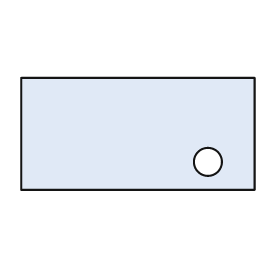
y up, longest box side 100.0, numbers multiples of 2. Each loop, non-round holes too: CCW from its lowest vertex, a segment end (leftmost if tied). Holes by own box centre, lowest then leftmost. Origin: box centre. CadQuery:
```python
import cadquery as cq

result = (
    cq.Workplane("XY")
    .moveTo(-50.0, -24.0)
    .lineTo(50.0, -24.0)
    .lineTo(50.0, 24.0)
    .lineTo(-50.0, 24.0)
    .close()
    .moveTo(30.0, -12.0)
    .circle(6.0)
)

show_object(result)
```